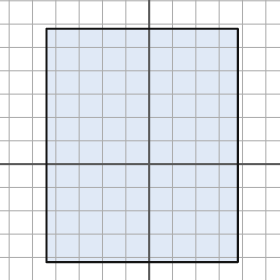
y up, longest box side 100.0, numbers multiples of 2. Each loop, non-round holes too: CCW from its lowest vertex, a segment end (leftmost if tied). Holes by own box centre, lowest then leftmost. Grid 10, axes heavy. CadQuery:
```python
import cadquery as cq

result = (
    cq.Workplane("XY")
    .moveTo(-44.0, -42.0)
    .lineTo(38.0, -42.0)
    .lineTo(38.0, 58.0)
    .lineTo(-44.0, 58.0)
    .close()
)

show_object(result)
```